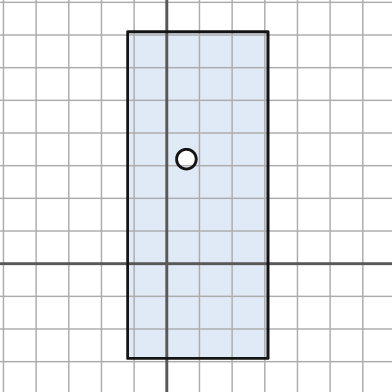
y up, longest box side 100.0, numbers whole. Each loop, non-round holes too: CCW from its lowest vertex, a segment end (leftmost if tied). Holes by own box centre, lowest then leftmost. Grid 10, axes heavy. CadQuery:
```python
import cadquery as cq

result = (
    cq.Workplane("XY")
    .moveTo(-12.0, -29.0)
    .lineTo(31.0, -29.0)
    .lineTo(31.0, 71.0)
    .lineTo(-12.0, 71.0)
    .close()
    .moveTo(6.0, 32.0)
    .circle(3.0)
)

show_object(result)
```